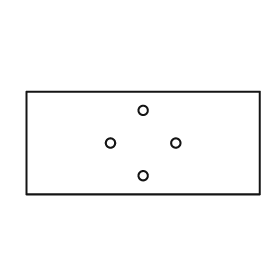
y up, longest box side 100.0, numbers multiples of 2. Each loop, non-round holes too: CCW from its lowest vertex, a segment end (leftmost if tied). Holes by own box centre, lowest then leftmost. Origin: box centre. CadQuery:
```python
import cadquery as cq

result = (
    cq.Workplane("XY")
    .moveTo(-50.0, -22.0)
    .lineTo(50.0, -22.0)
    .lineTo(50.0, 22.0)
    .lineTo(-50.0, 22.0)
    .close()
    .moveTo(0.0, -14.0)
    .circle(2.0)
    .moveTo(-14.0, 0.0)
    .circle(2.0)
    .moveTo(14.0, 0.0)
    .circle(2.0)
    .moveTo(0.0, 14.0)
    .circle(2.0)
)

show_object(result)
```